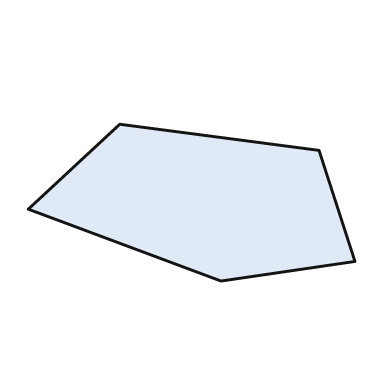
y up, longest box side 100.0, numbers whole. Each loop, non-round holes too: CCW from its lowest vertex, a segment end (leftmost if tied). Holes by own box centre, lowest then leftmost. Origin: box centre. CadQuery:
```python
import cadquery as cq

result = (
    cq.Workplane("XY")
    .moveTo(9.0, -24.0)
    .lineTo(50.0, -18.0)
    .lineTo(39.0, 16.0)
    .lineTo(-22.0, 24.0)
    .lineTo(-50.0, -2.0)
    .close()
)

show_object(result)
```